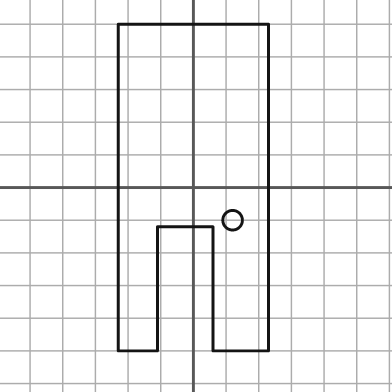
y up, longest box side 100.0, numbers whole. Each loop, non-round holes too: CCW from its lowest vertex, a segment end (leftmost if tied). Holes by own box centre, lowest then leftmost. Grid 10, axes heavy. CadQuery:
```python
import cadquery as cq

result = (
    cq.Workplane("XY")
    .moveTo(-23.0, -50.0)
    .lineTo(-11.0, -50.0)
    .lineTo(-11.0, -12.0)
    .lineTo(6.0, -12.0)
    .lineTo(6.0, -50.0)
    .lineTo(23.0, -50.0)
    .lineTo(23.0, 50.0)
    .lineTo(-23.0, 50.0)
    .close()
    .moveTo(12.0, -10.0)
    .circle(3.0)
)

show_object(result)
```